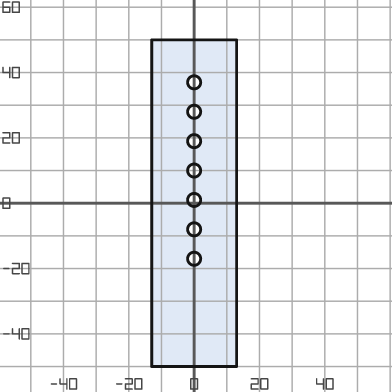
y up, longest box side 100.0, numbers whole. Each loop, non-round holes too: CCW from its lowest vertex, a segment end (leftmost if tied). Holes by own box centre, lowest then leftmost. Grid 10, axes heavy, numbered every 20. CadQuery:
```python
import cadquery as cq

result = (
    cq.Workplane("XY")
    .moveTo(-13.0, -50.0)
    .lineTo(13.0, -50.0)
    .lineTo(13.0, 50.0)
    .lineTo(-13.0, 50.0)
    .close()
    .moveTo(0.0, -17.0)
    .circle(2.0)
    .moveTo(0.0, -8.0)
    .circle(2.0)
    .moveTo(0.0, 1.0)
    .circle(2.0)
    .moveTo(0.0, 10.0)
    .circle(2.0)
    .moveTo(0.0, 19.0)
    .circle(2.0)
    .moveTo(0.0, 28.0)
    .circle(2.0)
    .moveTo(0.0, 37.0)
    .circle(2.0)
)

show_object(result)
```